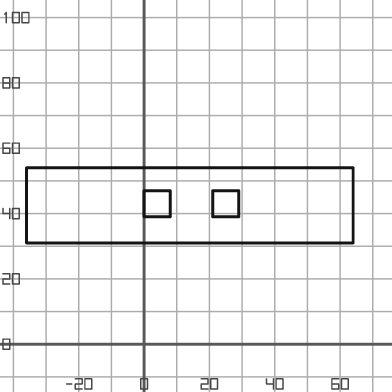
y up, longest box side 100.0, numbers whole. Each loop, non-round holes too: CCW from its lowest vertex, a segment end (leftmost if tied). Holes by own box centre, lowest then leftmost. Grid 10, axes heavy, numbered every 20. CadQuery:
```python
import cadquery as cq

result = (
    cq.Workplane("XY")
    .moveTo(-36.0, 31.0)
    .lineTo(64.0, 31.0)
    .lineTo(64.0, 54.0)
    .lineTo(-36.0, 54.0)
    .close()
    .moveTo(0.0, 39.0)
    .lineTo(8.0, 39.0)
    .lineTo(8.0, 47.0)
    .lineTo(0.0, 47.0)
    .close()
    .moveTo(21.0, 39.0)
    .lineTo(29.0, 39.0)
    .lineTo(29.0, 47.0)
    .lineTo(21.0, 47.0)
    .close()
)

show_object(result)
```